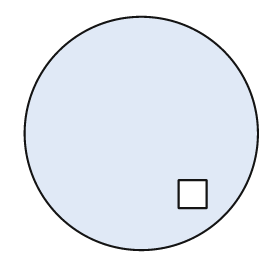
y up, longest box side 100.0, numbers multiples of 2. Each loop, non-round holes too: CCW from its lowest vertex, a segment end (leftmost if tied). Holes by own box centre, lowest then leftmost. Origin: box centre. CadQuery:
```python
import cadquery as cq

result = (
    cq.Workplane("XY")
    .moveTo(0.0, 0.0)
    .circle(50.0)
    .moveTo(16.0, -32.0)
    .lineTo(28.0, -32.0)
    .lineTo(28.0, -20.0)
    .lineTo(16.0, -20.0)
    .close()
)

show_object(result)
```